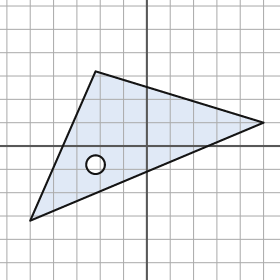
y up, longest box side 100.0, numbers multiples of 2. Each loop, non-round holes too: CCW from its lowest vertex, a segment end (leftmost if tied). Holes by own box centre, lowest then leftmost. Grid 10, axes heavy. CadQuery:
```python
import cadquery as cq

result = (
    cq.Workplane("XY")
    .moveTo(-50.0, -32.0)
    .lineTo(50.0, 10.0)
    .lineTo(-22.0, 32.0)
    .close()
    .moveTo(-22.0, -8.0)
    .circle(4.0)
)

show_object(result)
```